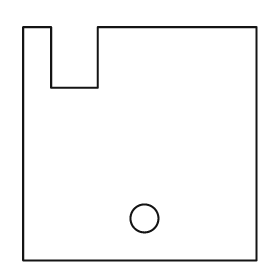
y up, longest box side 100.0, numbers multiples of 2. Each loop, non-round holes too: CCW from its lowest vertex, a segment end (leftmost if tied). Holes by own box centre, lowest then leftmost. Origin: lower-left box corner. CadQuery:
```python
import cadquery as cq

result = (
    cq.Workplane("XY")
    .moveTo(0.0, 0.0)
    .lineTo(100.0, 0.0)
    .lineTo(100.0, 100.0)
    .lineTo(32.0, 100.0)
    .lineTo(32.0, 74.0)
    .lineTo(12.0, 74.0)
    .lineTo(12.0, 100.0)
    .lineTo(0.0, 100.0)
    .close()
    .moveTo(52.0, 18.0)
    .circle(6.0)
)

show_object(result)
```